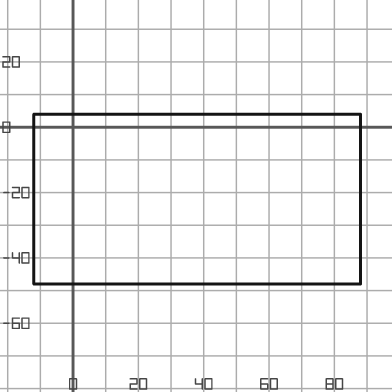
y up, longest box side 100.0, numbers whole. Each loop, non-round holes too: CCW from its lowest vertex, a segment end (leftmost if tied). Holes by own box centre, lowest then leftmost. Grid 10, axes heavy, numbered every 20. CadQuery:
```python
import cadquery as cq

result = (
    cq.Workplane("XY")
    .moveTo(-12.0, -48.0)
    .lineTo(88.0, -48.0)
    .lineTo(88.0, 4.0)
    .lineTo(-12.0, 4.0)
    .close()
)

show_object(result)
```